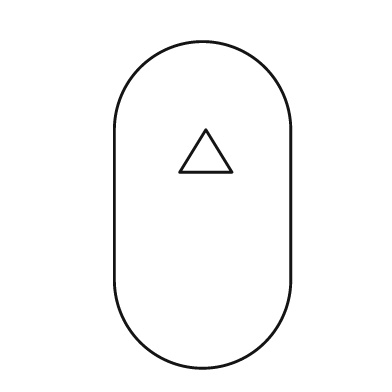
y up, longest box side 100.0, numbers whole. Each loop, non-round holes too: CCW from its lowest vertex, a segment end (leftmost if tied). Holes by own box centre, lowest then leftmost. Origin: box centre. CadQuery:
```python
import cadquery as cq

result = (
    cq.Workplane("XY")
    .moveTo(-27.0, -23.0)
    .threePointArc((0.0, -50.0), (27.0, -23.0))
    .lineTo(27.0, 23.0)
    .threePointArc((0.0, 50.0), (-27.0, 23.0))
    .close()
    .moveTo(-7.0, 10.0)
    .lineTo(9.0, 10.0)
    .lineTo(1.0, 23.0)
    .close()
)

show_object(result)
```